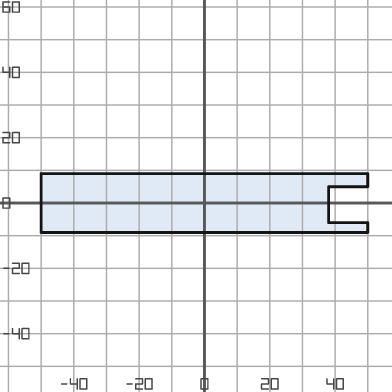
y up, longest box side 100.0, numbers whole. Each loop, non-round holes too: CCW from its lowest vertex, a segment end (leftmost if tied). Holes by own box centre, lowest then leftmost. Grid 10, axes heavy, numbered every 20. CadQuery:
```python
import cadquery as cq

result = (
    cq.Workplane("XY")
    .moveTo(-50.0, -9.0)
    .lineTo(50.0, -9.0)
    .lineTo(50.0, -6.0)
    .lineTo(38.0, -6.0)
    .lineTo(38.0, 5.0)
    .lineTo(50.0, 5.0)
    .lineTo(50.0, 9.0)
    .lineTo(-50.0, 9.0)
    .close()
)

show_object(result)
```